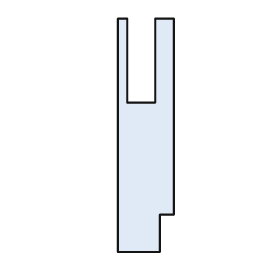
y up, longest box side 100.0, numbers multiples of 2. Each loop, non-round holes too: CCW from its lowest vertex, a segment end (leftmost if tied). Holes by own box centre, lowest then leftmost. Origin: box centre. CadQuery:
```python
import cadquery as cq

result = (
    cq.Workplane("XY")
    .moveTo(-12.0, -50.0)
    .lineTo(6.0, -50.0)
    .lineTo(6.0, -34.0)
    .lineTo(12.0, -34.0)
    .lineTo(12.0, 50.0)
    .lineTo(4.0, 50.0)
    .lineTo(4.0, 14.0)
    .lineTo(-8.0, 14.0)
    .lineTo(-8.0, 50.0)
    .lineTo(-12.0, 50.0)
    .close()
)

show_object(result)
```